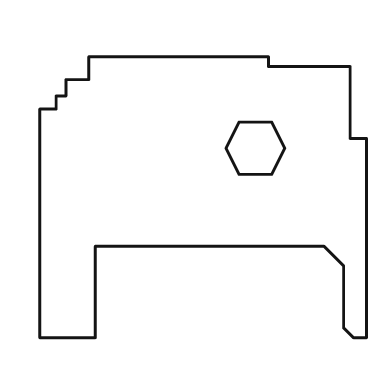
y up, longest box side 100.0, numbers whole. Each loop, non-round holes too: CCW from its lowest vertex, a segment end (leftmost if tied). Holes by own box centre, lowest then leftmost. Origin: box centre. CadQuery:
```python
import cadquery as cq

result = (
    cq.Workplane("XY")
    .moveTo(-50.0, -43.0)
    .lineTo(-33.0, -43.0)
    .lineTo(-33.0, -15.0)
    .lineTo(37.0, -15.0)
    .lineTo(43.0, -21.0)
    .lineTo(43.0, -40.0)
    .lineTo(46.0, -43.0)
    .lineTo(50.0, -43.0)
    .lineTo(50.0, 18.0)
    .lineTo(45.0, 18.0)
    .lineTo(45.0, 40.0)
    .lineTo(20.0, 40.0)
    .lineTo(20.0, 43.0)
    .lineTo(-35.0, 43.0)
    .lineTo(-35.0, 36.0)
    .lineTo(-42.0, 36.0)
    .lineTo(-42.0, 31.0)
    .lineTo(-45.0, 31.0)
    .lineTo(-45.0, 27.0)
    .lineTo(-50.0, 27.0)
    .close()
    .moveTo(11.0, 7.0)
    .lineTo(21.0, 7.0)
    .lineTo(25.0, 15.0)
    .lineTo(21.0, 23.0)
    .lineTo(11.0, 23.0)
    .lineTo(7.0, 15.0)
    .close()
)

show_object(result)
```